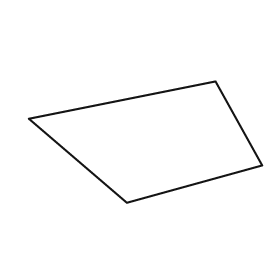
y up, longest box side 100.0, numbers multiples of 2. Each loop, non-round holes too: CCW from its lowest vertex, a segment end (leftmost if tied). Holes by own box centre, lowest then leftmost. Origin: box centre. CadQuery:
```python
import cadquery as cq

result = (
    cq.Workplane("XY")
    .moveTo(-8.0, -26.0)
    .lineTo(50.0, -10.0)
    .lineTo(30.0, 26.0)
    .lineTo(-50.0, 10.0)
    .close()
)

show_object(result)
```